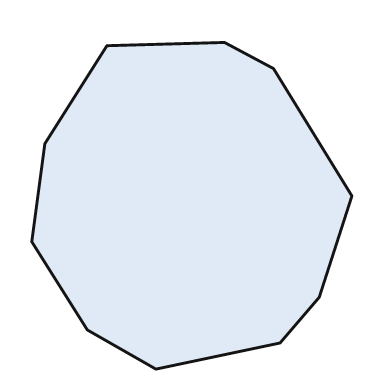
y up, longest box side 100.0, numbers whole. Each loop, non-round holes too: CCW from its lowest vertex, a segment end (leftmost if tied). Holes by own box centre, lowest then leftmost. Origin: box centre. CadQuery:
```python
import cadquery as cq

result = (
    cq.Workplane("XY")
    .moveTo(-11.0, -50.0)
    .lineTo(27.0, -42.0)
    .lineTo(39.0, -28.0)
    .lineTo(49.0, 3.0)
    .lineTo(25.0, 42.0)
    .lineTo(10.0, 50.0)
    .lineTo(-26.0, 49.0)
    .lineTo(-45.0, 19.0)
    .lineTo(-49.0, -11.0)
    .lineTo(-32.0, -38.0)
    .close()
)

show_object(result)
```